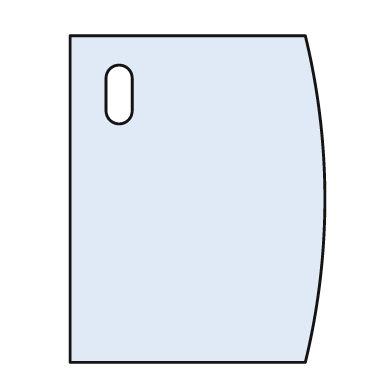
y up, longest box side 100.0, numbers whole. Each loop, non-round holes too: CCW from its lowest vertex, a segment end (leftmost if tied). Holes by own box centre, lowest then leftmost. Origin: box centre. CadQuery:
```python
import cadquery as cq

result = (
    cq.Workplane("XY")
    .moveTo(-39.0, -50.0)
    .lineTo(33.0, -50.0)
    .threePointArc((39.0, 0.0), (33.0, 50.0))
    .lineTo(-39.0, 50.0)
    .close()
    .moveTo(-28.0, 27.0)
    .threePointArc((-24.0, 23.0), (-20.0, 27.0))
    .lineTo(-20.0, 37.0)
    .threePointArc((-24.0, 41.0), (-28.0, 37.0))
    .close()
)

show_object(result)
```